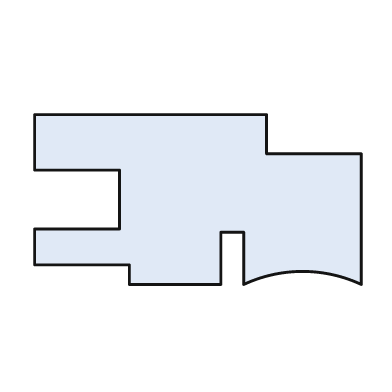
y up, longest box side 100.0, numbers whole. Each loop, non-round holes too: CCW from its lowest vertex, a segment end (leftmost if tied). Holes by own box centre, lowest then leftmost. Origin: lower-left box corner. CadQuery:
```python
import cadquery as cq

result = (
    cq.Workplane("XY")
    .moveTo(29.0, 0.0)
    .lineTo(57.0, 0.0)
    .lineTo(57.0, 16.0)
    .lineTo(64.0, 16.0)
    .lineTo(64.0, 0.0)
    .threePointArc((82.0, 4.0), (100.0, 0.0))
    .lineTo(100.0, 40.0)
    .lineTo(71.0, 40.0)
    .lineTo(71.0, 52.0)
    .lineTo(0.0, 52.0)
    .lineTo(0.0, 35.0)
    .lineTo(26.0, 35.0)
    .lineTo(26.0, 17.0)
    .lineTo(0.0, 17.0)
    .lineTo(0.0, 6.0)
    .lineTo(29.0, 6.0)
    .close()
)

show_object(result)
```